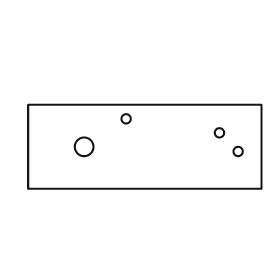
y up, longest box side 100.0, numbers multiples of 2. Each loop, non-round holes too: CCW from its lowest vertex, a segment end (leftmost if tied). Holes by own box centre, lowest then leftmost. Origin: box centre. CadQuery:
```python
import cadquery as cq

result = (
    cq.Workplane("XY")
    .moveTo(-50.0, -18.0)
    .lineTo(50.0, -18.0)
    .lineTo(50.0, 18.0)
    .lineTo(-50.0, 18.0)
    .close()
    .moveTo(40.0, -2.0)
    .circle(2.0)
    .moveTo(-26.0, 0.0)
    .circle(4.0)
    .moveTo(32.0, 6.0)
    .circle(2.0)
    .moveTo(-8.0, 12.0)
    .circle(2.0)
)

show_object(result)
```